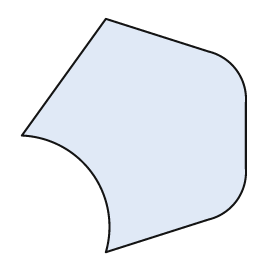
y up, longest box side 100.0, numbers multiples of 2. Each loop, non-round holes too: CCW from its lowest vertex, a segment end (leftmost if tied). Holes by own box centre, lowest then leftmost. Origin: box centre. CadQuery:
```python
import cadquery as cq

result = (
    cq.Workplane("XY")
    .moveTo(-12.0, -50.0)
    .lineTo(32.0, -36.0)
    .threePointArc((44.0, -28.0), (48.0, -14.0))
    .lineTo(48.0, 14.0)
    .threePointArc((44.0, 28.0), (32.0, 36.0))
    .lineTo(-12.0, 50.0)
    .lineTo(-48.0, 0.0)
    .threePointArc((-18.0, -16.0), (-12.0, -50.0))
    .close()
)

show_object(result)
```